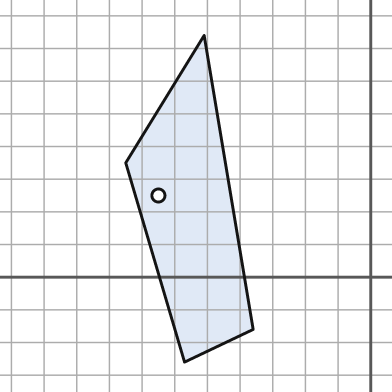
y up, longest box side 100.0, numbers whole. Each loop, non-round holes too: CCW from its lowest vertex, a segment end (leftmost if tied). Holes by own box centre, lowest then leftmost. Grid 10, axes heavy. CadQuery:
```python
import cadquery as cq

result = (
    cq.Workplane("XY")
    .moveTo(-57.0, -26.0)
    .lineTo(-36.0, -16.0)
    .lineTo(-51.0, 74.0)
    .lineTo(-75.0, 35.0)
    .close()
    .moveTo(-65.0, 25.0)
    .circle(2.0)
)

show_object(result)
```